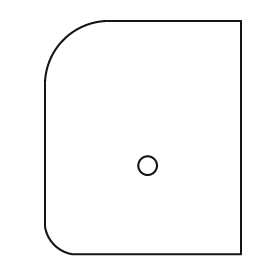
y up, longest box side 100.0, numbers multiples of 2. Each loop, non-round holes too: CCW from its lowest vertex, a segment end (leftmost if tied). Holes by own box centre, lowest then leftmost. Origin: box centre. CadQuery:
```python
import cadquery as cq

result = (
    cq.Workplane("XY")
    .moveTo(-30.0, -50.0)
    .lineTo(42.0, -50.0)
    .lineTo(42.0, 50.0)
    .lineTo(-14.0, 50.0)
    .threePointArc((-34.0, 42.0), (-42.0, 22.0))
    .lineTo(-42.0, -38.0)
    .threePointArc((-38.0, -46.0), (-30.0, -50.0))
    .close()
    .moveTo(2.0, -12.0)
    .circle(4.0)
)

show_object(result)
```